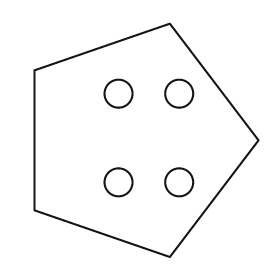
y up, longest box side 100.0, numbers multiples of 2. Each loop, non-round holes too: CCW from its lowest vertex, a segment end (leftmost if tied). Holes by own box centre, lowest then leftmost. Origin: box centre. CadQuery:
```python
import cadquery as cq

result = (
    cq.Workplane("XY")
    .moveTo(10.0, -50.0)
    .lineTo(48.0, 0.0)
    .lineTo(10.0, 50.0)
    .lineTo(-48.0, 30.0)
    .lineTo(-48.0, -30.0)
    .close()
    .moveTo(-12.0, -18.0)
    .circle(6.0)
    .moveTo(14.0, -18.0)
    .circle(6.0)
    .moveTo(-12.0, 20.0)
    .circle(6.0)
    .moveTo(14.0, 20.0)
    .circle(6.0)
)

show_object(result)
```